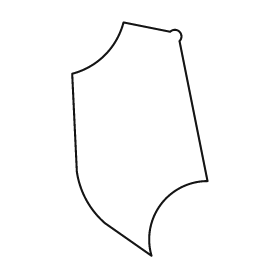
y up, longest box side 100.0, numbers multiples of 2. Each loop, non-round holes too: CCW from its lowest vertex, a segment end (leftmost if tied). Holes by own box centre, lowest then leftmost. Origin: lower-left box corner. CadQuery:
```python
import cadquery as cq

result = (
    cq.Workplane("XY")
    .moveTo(34.0, 0.0)
    .threePointArc((38.0, 22.0), (58.0, 32.0))
    .lineTo(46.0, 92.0)
    .threePointArc((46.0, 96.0), (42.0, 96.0))
    .lineTo(22.0, 100.0)
    .threePointArc((14.0, 86.0), (0.0, 78.0))
    .lineTo(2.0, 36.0)
    .threePointArc((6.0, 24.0), (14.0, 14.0))
    .close()
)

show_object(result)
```